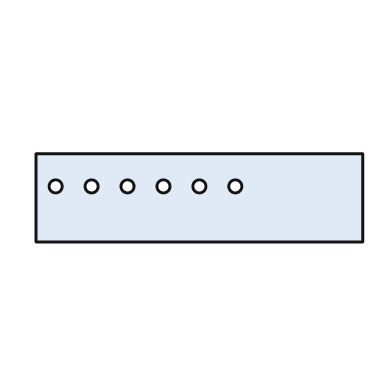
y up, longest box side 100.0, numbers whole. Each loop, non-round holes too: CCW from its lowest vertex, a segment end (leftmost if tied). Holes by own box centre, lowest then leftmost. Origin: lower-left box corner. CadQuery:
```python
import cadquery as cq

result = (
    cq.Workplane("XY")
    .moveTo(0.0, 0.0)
    .lineTo(100.0, 0.0)
    .lineTo(100.0, 27.0)
    .lineTo(0.0, 27.0)
    .close()
    .moveTo(6.0, 17.0)
    .circle(2.0)
    .moveTo(17.0, 17.0)
    .circle(2.0)
    .moveTo(28.0, 17.0)
    .circle(2.0)
    .moveTo(39.0, 17.0)
    .circle(2.0)
    .moveTo(50.0, 17.0)
    .circle(2.0)
    .moveTo(61.0, 17.0)
    .circle(2.0)
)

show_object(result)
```